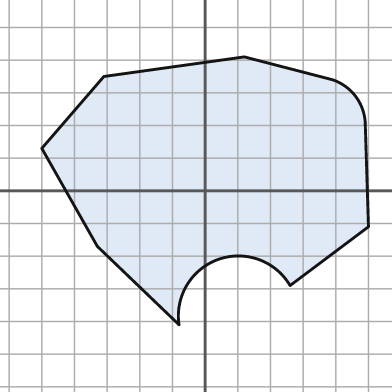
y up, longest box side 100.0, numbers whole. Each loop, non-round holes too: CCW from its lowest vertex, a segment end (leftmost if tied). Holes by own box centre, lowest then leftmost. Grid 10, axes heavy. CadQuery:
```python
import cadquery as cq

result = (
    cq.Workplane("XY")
    .moveTo(-8.0, -41.0)
    .threePointArc((4.0, -21.0), (26.0, -29.0))
    .lineTo(50.0, -11.0)
    .lineTo(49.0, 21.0)
    .threePointArc((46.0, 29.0), (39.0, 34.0))
    .lineTo(12.0, 41.0)
    .lineTo(-31.0, 35.0)
    .lineTo(-50.0, 13.0)
    .lineTo(-33.0, -17.0)
    .close()
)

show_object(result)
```